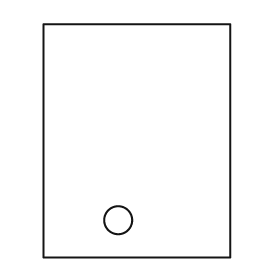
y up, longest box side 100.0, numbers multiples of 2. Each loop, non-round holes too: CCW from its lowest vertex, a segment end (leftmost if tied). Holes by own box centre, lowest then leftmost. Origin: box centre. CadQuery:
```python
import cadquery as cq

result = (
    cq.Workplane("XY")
    .moveTo(-40.0, -50.0)
    .lineTo(40.0, -50.0)
    .lineTo(40.0, 50.0)
    .lineTo(-40.0, 50.0)
    .close()
    .moveTo(-8.0, -34.0)
    .circle(6.0)
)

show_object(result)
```